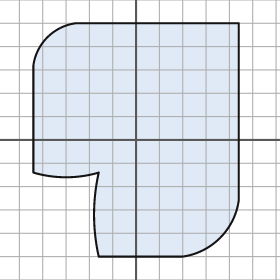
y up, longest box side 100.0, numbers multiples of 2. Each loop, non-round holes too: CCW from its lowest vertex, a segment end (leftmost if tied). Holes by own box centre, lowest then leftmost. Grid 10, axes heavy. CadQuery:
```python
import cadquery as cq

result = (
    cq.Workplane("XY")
    .moveTo(-16.0, -50.0)
    .lineTo(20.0, -50.0)
    .threePointArc((36.0, -42.0), (44.0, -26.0))
    .lineTo(44.0, 50.0)
    .lineTo(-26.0, 50.0)
    .threePointArc((-38.0, 44.0), (-44.0, 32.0))
    .lineTo(-44.0, -14.0)
    .threePointArc((-30.0, -16.0), (-16.0, -14.0))
    .threePointArc((-18.0, -32.0), (-16.0, -50.0))
    .close()
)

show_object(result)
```